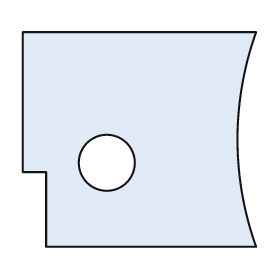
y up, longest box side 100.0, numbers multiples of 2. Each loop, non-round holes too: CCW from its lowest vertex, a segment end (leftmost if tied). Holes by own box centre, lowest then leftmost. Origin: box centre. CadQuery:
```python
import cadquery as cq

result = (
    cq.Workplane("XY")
    .moveTo(-40.0, -46.0)
    .lineTo(50.0, -46.0)
    .threePointArc((42.0, 0.0), (50.0, 46.0))
    .lineTo(-50.0, 46.0)
    .lineTo(-50.0, -14.0)
    .lineTo(-40.0, -14.0)
    .close()
    .moveTo(-14.0, -10.0)
    .circle(12.0)
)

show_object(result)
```